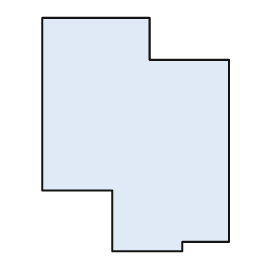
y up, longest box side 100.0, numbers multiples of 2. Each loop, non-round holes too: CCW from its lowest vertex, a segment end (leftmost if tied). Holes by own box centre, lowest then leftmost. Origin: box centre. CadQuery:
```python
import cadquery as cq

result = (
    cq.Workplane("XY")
    .moveTo(-10.0, -50.0)
    .lineTo(20.0, -50.0)
    .lineTo(20.0, -46.0)
    .lineTo(40.0, -46.0)
    .lineTo(40.0, 32.0)
    .lineTo(6.0, 32.0)
    .lineTo(6.0, 50.0)
    .lineTo(-40.0, 50.0)
    .lineTo(-40.0, -24.0)
    .lineTo(-10.0, -24.0)
    .close()
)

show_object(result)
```